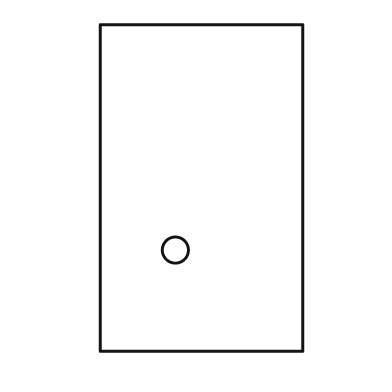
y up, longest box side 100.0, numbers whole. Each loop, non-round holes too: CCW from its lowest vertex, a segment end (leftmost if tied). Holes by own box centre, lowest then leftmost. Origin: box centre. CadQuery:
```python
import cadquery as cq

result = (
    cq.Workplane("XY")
    .moveTo(-31.0, -50.0)
    .lineTo(31.0, -50.0)
    .lineTo(31.0, 50.0)
    .lineTo(-31.0, 50.0)
    .close()
    .moveTo(-8.0, -19.0)
    .circle(4.0)
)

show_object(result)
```